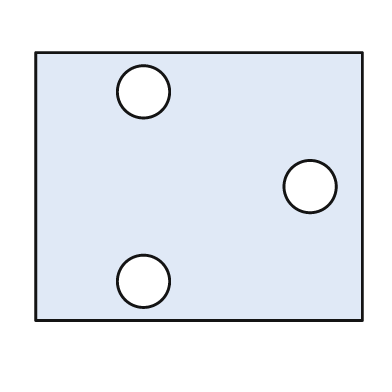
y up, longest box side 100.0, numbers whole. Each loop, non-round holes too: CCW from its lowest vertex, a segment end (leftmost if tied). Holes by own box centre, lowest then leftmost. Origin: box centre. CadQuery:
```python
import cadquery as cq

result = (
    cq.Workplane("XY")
    .moveTo(-50.0, -41.0)
    .lineTo(50.0, -41.0)
    .lineTo(50.0, 41.0)
    .lineTo(-50.0, 41.0)
    .close()
    .moveTo(-17.0, -29.0)
    .circle(8.0)
    .moveTo(34.0, 0.0)
    .circle(8.0)
    .moveTo(-17.0, 29.0)
    .circle(8.0)
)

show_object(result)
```